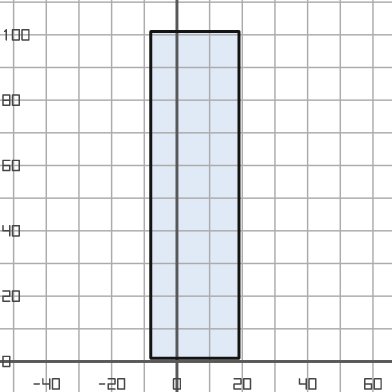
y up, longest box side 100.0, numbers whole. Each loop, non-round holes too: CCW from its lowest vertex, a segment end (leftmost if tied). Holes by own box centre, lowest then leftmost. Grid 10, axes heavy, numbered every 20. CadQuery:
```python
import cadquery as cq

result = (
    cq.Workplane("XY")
    .moveTo(-8.0, 1.0)
    .lineTo(19.0, 1.0)
    .lineTo(19.0, 101.0)
    .lineTo(-8.0, 101.0)
    .close()
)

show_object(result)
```